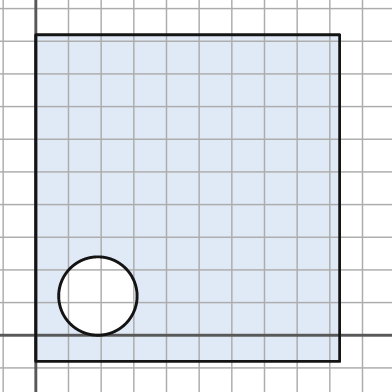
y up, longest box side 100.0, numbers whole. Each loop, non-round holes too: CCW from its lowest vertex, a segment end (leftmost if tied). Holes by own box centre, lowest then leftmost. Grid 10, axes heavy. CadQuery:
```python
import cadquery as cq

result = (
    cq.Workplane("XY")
    .moveTo(0.0, -8.0)
    .lineTo(93.0, -8.0)
    .lineTo(93.0, 92.0)
    .lineTo(0.0, 92.0)
    .close()
    .moveTo(19.0, 12.0)
    .circle(12.0)
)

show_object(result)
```